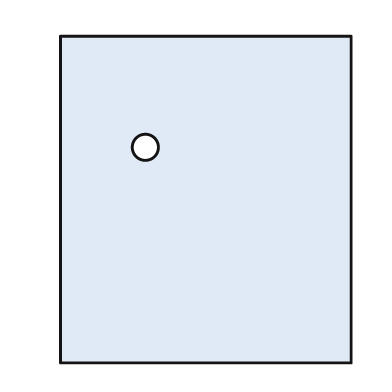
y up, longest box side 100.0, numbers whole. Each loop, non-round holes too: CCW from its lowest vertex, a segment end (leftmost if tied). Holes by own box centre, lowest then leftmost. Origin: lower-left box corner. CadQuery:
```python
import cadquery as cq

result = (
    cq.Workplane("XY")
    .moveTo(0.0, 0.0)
    .lineTo(89.0, 0.0)
    .lineTo(89.0, 100.0)
    .lineTo(0.0, 100.0)
    .close()
    .moveTo(26.0, 66.0)
    .circle(4.0)
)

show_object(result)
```